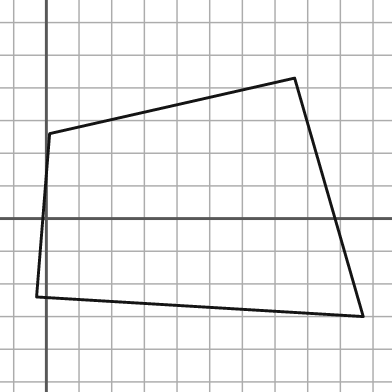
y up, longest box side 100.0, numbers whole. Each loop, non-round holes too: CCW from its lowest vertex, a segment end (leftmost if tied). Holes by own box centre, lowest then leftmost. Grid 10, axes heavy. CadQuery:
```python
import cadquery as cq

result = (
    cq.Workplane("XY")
    .moveTo(97.0, -30.0)
    .lineTo(76.0, 43.0)
    .lineTo(1.0, 26.0)
    .lineTo(-3.0, -24.0)
    .close()
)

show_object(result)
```